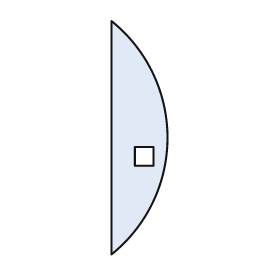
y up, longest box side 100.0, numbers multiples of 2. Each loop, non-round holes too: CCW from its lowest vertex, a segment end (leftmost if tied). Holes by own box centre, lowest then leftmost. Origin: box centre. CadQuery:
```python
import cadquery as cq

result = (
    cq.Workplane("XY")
    .moveTo(-12.0, -50.0)
    .threePointArc((12.0, 0.0), (-12.0, 50.0))
    .close()
    .moveTo(-2.0, -12.0)
    .lineTo(6.0, -12.0)
    .lineTo(6.0, -4.0)
    .lineTo(-2.0, -4.0)
    .close()
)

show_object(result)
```